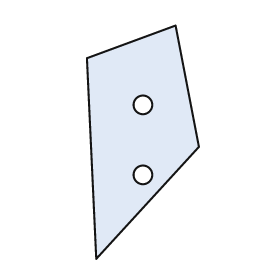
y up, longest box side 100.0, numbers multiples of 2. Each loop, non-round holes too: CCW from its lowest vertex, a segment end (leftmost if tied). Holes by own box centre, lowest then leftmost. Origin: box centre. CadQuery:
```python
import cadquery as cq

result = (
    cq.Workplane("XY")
    .moveTo(-20.0, -50.0)
    .lineTo(24.0, -2.0)
    .lineTo(14.0, 50.0)
    .lineTo(-24.0, 36.0)
    .close()
    .moveTo(0.0, -14.0)
    .circle(4.0)
    .moveTo(0.0, 16.0)
    .circle(4.0)
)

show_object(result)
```